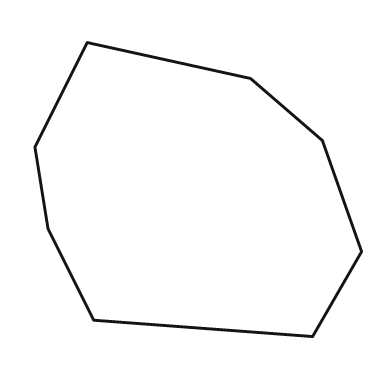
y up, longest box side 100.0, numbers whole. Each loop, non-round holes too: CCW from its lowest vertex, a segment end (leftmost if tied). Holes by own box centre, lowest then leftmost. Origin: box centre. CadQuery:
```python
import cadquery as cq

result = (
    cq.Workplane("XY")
    .moveTo(35.0, -45.0)
    .lineTo(50.0, -19.0)
    .lineTo(38.0, 15.0)
    .lineTo(16.0, 34.0)
    .lineTo(-34.0, 45.0)
    .lineTo(-50.0, 13.0)
    .lineTo(-46.0, -12.0)
    .lineTo(-32.0, -40.0)
    .close()
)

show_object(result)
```